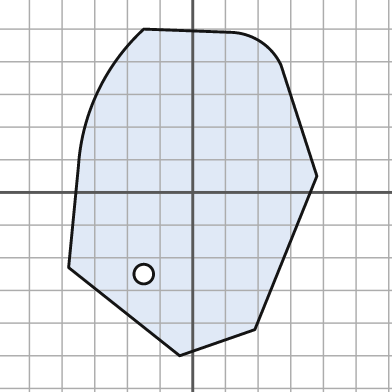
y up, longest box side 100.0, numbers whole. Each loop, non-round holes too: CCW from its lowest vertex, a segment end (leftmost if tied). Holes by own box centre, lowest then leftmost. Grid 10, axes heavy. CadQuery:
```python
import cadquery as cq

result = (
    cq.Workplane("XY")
    .moveTo(-4.0, -50.0)
    .lineTo(19.0, -42.0)
    .lineTo(38.0, 5.0)
    .lineTo(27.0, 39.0)
    .threePointArc((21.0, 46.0), (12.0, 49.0))
    .lineTo(-15.0, 50.0)
    .threePointArc((-29.0, 31.0), (-35.0, 8.0))
    .lineTo(-38.0, -23.0)
    .close()
    .moveTo(-15.0, -25.0)
    .circle(3.0)
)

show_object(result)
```